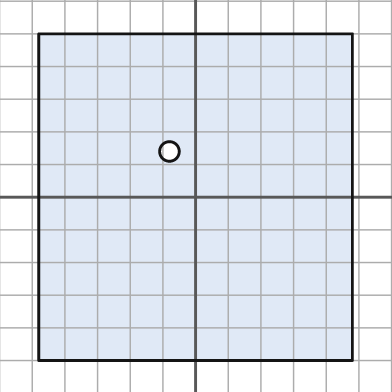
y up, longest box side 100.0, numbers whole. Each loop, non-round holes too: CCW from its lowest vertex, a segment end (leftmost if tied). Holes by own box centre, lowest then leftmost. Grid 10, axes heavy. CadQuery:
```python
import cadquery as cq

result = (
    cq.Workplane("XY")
    .moveTo(-48.0, -50.0)
    .lineTo(48.0, -50.0)
    .lineTo(48.0, 50.0)
    .lineTo(-48.0, 50.0)
    .close()
    .moveTo(-8.0, 14.0)
    .circle(3.0)
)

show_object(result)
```